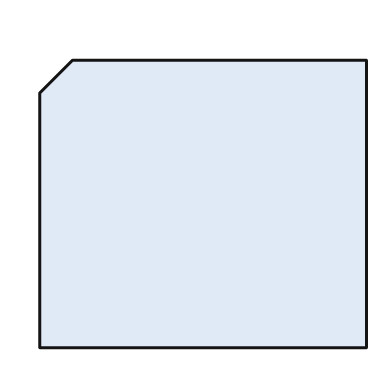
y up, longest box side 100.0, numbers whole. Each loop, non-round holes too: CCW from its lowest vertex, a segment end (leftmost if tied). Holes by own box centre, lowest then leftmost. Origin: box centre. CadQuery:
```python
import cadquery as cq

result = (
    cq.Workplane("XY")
    .moveTo(-50.0, -44.0)
    .lineTo(50.0, -44.0)
    .lineTo(50.0, 44.0)
    .lineTo(-40.0, 44.0)
    .lineTo(-50.0, 34.0)
    .close()
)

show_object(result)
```